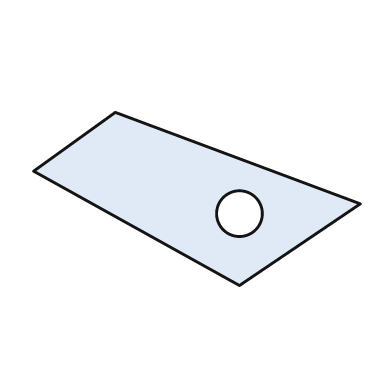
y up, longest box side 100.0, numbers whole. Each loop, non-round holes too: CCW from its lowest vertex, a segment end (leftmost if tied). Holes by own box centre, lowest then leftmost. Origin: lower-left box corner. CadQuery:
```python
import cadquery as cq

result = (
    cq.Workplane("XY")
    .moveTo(63.0, 0.0)
    .lineTo(100.0, 25.0)
    .lineTo(25.0, 53.0)
    .lineTo(0.0, 35.0)
    .close()
    .moveTo(63.0, 22.0)
    .circle(7.0)
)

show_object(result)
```